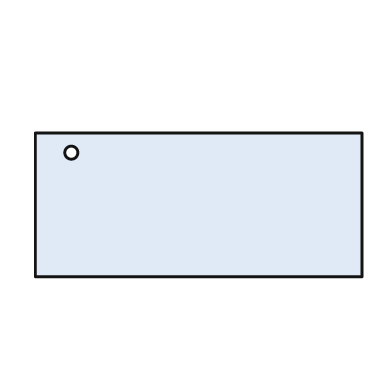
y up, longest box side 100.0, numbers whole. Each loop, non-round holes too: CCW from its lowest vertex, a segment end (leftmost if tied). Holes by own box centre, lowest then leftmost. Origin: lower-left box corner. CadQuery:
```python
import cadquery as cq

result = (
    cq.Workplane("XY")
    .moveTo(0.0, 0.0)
    .lineTo(100.0, 0.0)
    .lineTo(100.0, 44.0)
    .lineTo(0.0, 44.0)
    .close()
    .moveTo(11.0, 38.0)
    .circle(2.0)
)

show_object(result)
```